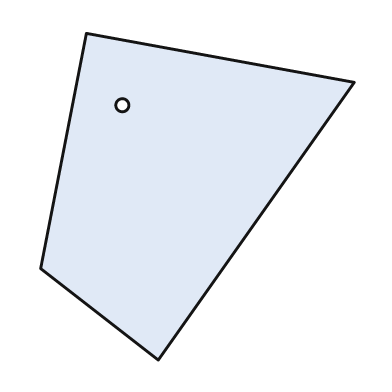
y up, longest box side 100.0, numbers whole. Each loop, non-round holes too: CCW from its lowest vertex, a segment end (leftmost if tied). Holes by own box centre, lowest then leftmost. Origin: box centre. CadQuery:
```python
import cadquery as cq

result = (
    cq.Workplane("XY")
    .moveTo(-12.0, -50.0)
    .lineTo(48.0, 35.0)
    .lineTo(-34.0, 50.0)
    .lineTo(-48.0, -22.0)
    .close()
    .moveTo(-23.0, 28.0)
    .circle(2.0)
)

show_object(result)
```